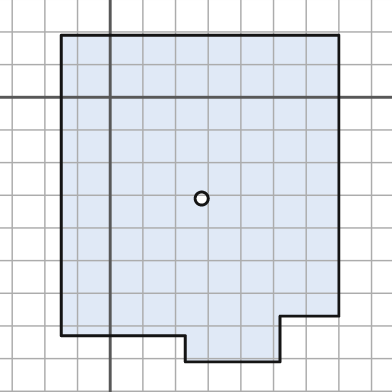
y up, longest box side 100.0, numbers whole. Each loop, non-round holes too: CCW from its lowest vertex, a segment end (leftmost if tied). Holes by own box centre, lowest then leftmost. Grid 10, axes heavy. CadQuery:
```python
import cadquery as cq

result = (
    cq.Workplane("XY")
    .moveTo(23.0, -81.0)
    .lineTo(52.0, -81.0)
    .lineTo(52.0, -67.0)
    .lineTo(70.0, -67.0)
    .lineTo(70.0, 19.0)
    .lineTo(-15.0, 19.0)
    .lineTo(-15.0, -73.0)
    .lineTo(23.0, -73.0)
    .close()
    .moveTo(28.0, -31.0)
    .circle(2.0)
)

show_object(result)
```